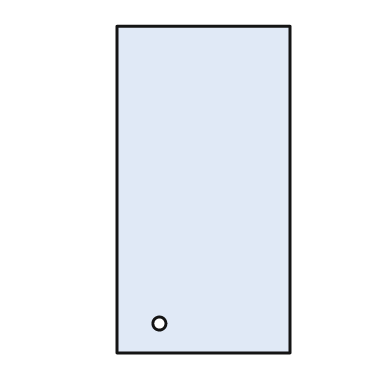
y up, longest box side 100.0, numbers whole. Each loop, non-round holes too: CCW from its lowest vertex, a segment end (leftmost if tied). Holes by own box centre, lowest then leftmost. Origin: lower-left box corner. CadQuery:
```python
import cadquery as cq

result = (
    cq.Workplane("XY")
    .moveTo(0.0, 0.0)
    .lineTo(53.0, 0.0)
    .lineTo(53.0, 100.0)
    .lineTo(0.0, 100.0)
    .close()
    .moveTo(13.0, 9.0)
    .circle(2.0)
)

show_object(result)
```